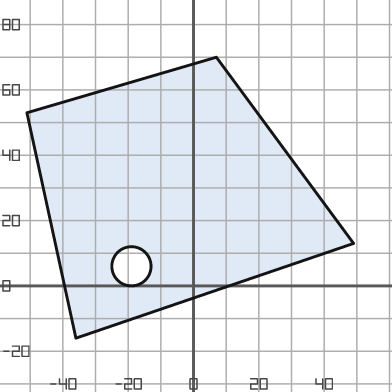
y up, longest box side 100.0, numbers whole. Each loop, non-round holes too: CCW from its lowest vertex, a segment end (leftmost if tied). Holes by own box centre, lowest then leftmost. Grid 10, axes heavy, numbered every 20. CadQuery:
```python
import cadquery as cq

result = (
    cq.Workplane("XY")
    .moveTo(-36.0, -16.0)
    .lineTo(49.0, 13.0)
    .lineTo(7.0, 70.0)
    .lineTo(-51.0, 53.0)
    .close()
    .moveTo(-19.0, 6.0)
    .circle(6.0)
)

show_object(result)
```